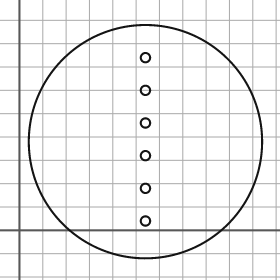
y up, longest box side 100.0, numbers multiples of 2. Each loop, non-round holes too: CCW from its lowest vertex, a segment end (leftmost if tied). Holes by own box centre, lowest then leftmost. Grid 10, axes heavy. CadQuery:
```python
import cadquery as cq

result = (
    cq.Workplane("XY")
    .moveTo(54.0, 38.0)
    .circle(50.0)
    .moveTo(54.0, 4.0)
    .circle(2.0)
    .moveTo(54.0, 18.0)
    .circle(2.0)
    .moveTo(54.0, 32.0)
    .circle(2.0)
    .moveTo(54.0, 46.0)
    .circle(2.0)
    .moveTo(54.0, 60.0)
    .circle(2.0)
    .moveTo(54.0, 74.0)
    .circle(2.0)
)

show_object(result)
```